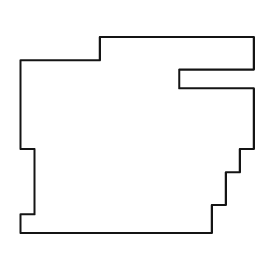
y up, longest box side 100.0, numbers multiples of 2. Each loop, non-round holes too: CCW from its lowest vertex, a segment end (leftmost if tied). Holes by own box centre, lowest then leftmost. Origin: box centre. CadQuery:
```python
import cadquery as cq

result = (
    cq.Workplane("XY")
    .moveTo(-50.0, -42.0)
    .lineTo(32.0, -42.0)
    .lineTo(32.0, -30.0)
    .lineTo(38.0, -30.0)
    .lineTo(38.0, -16.0)
    .lineTo(44.0, -16.0)
    .lineTo(44.0, -6.0)
    .lineTo(50.0, -6.0)
    .lineTo(50.0, 20.0)
    .lineTo(18.0, 20.0)
    .lineTo(18.0, 28.0)
    .lineTo(50.0, 28.0)
    .lineTo(50.0, 42.0)
    .lineTo(-16.0, 42.0)
    .lineTo(-16.0, 32.0)
    .lineTo(-50.0, 32.0)
    .lineTo(-50.0, -6.0)
    .lineTo(-44.0, -6.0)
    .lineTo(-44.0, -34.0)
    .lineTo(-50.0, -34.0)
    .close()
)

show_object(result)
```